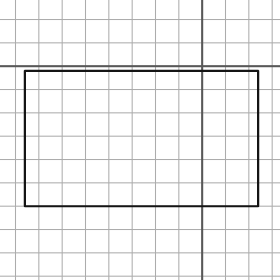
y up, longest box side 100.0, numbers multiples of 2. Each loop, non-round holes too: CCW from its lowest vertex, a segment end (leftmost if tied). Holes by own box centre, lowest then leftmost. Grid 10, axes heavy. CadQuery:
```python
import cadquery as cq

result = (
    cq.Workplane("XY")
    .moveTo(-76.0, -60.0)
    .lineTo(24.0, -60.0)
    .lineTo(24.0, -2.0)
    .lineTo(-76.0, -2.0)
    .close()
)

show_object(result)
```